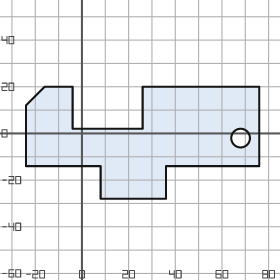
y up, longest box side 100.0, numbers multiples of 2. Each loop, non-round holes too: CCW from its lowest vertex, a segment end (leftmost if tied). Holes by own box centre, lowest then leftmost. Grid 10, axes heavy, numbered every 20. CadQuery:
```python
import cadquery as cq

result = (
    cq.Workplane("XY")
    .moveTo(8.0, -28.0)
    .lineTo(36.0, -28.0)
    .lineTo(36.0, -14.0)
    .lineTo(76.0, -14.0)
    .lineTo(76.0, 20.0)
    .lineTo(26.0, 20.0)
    .lineTo(26.0, 2.0)
    .lineTo(-4.0, 2.0)
    .lineTo(-4.0, 20.0)
    .lineTo(-16.0, 20.0)
    .lineTo(-24.0, 12.0)
    .lineTo(-24.0, -14.0)
    .lineTo(8.0, -14.0)
    .close()
    .moveTo(68.0, -2.0)
    .circle(4.0)
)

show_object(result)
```